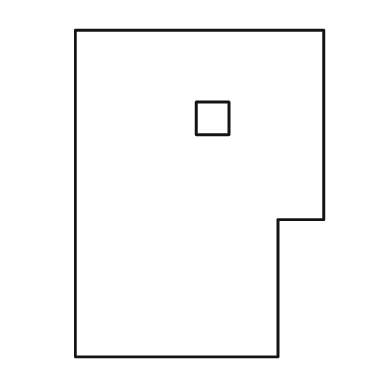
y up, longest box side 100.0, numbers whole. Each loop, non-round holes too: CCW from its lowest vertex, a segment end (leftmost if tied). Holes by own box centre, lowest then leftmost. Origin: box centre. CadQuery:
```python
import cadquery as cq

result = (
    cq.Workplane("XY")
    .moveTo(-38.0, -50.0)
    .lineTo(24.0, -50.0)
    .lineTo(24.0, -8.0)
    .lineTo(38.0, -8.0)
    .lineTo(38.0, 50.0)
    .lineTo(-38.0, 50.0)
    .close()
    .moveTo(-1.0, 18.0)
    .lineTo(9.0, 18.0)
    .lineTo(9.0, 28.0)
    .lineTo(-1.0, 28.0)
    .close()
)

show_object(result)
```